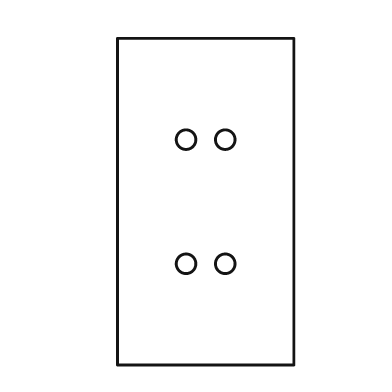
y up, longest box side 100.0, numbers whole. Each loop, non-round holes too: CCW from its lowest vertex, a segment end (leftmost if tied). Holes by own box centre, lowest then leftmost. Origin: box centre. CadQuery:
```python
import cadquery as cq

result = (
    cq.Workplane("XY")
    .moveTo(-27.0, -50.0)
    .lineTo(27.0, -50.0)
    .lineTo(27.0, 50.0)
    .lineTo(-27.0, 50.0)
    .close()
    .moveTo(-6.0, -19.0)
    .circle(3.0)
    .moveTo(6.0, -19.0)
    .circle(3.0)
    .moveTo(-6.0, 19.0)
    .circle(3.0)
    .moveTo(6.0, 19.0)
    .circle(3.0)
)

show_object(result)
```